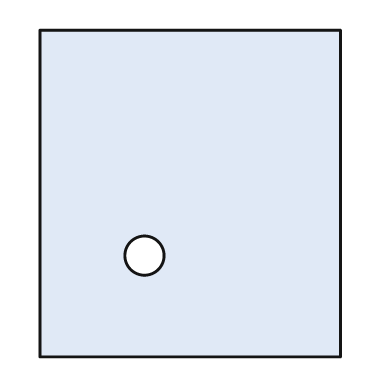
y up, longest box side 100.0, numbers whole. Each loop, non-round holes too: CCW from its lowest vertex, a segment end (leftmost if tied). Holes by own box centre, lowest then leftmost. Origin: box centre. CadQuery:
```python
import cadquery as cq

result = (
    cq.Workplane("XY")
    .moveTo(-46.0, -50.0)
    .lineTo(46.0, -50.0)
    .lineTo(46.0, 50.0)
    .lineTo(-46.0, 50.0)
    .close()
    .moveTo(-14.0, -19.0)
    .circle(6.0)
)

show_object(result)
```